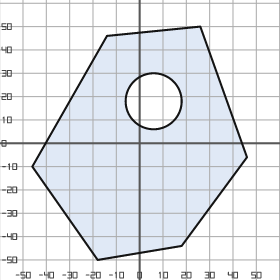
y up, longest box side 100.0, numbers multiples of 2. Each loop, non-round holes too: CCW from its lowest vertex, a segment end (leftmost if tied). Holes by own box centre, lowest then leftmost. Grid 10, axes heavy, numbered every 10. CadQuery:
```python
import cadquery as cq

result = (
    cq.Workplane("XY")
    .moveTo(-18.0, -50.0)
    .lineTo(18.0, -44.0)
    .lineTo(46.0, -6.0)
    .lineTo(26.0, 50.0)
    .lineTo(-14.0, 46.0)
    .lineTo(-46.0, -10.0)
    .close()
    .moveTo(6.0, 18.0)
    .circle(12.0)
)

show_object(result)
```